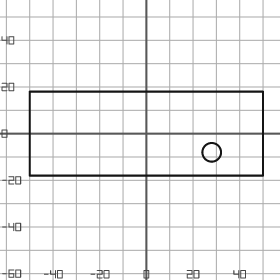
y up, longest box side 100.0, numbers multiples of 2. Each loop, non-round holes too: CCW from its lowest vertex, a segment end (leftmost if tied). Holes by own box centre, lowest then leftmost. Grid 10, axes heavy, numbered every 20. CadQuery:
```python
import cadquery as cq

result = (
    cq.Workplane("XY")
    .moveTo(-50.0, -18.0)
    .lineTo(50.0, -18.0)
    .lineTo(50.0, 18.0)
    .lineTo(-50.0, 18.0)
    .close()
    .moveTo(28.0, -8.0)
    .circle(4.0)
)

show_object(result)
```